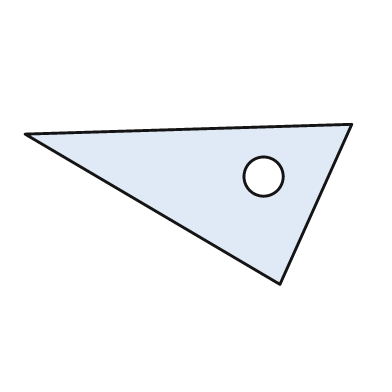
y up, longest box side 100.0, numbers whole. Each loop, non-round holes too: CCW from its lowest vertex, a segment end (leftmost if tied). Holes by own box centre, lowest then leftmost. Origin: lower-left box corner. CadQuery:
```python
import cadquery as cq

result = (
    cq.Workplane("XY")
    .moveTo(78.0, 0.0)
    .lineTo(100.0, 49.0)
    .lineTo(0.0, 46.0)
    .close()
    .moveTo(73.0, 33.0)
    .circle(6.0)
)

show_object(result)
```